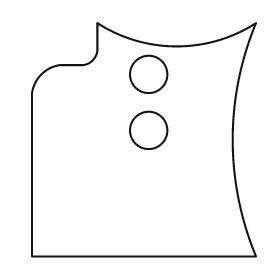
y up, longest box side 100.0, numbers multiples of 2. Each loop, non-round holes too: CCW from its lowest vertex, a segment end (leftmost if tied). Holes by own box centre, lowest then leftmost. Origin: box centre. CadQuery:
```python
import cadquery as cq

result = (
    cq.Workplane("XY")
    .moveTo(-48.0, -50.0)
    .lineTo(48.0, -50.0)
    .threePointArc((38.0, 0.0), (48.0, 50.0))
    .threePointArc((14.0, 40.0), (-20.0, 50.0))
    .lineTo(-20.0, 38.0)
    .threePointArc((-22.0, 34.0), (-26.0, 32.0))
    .lineTo(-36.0, 32.0)
    .threePointArc((-44.0, 28.0), (-48.0, 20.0))
    .close()
    .moveTo(2.0, 4.0)
    .circle(8.0)
    .moveTo(2.0, 28.0)
    .circle(8.0)
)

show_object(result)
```